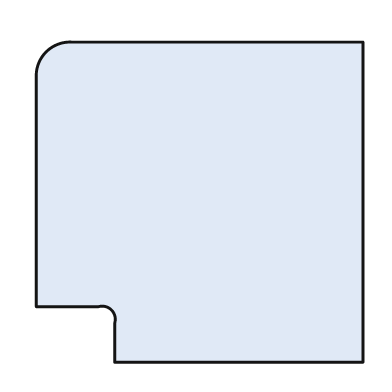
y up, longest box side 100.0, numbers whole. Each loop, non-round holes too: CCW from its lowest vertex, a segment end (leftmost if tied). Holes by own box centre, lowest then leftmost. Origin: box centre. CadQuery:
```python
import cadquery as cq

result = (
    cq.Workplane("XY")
    .moveTo(-26.0, -49.0)
    .lineTo(50.0, -49.0)
    .lineTo(50.0, 49.0)
    .lineTo(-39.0, 49.0)
    .threePointArc((-47.0, 46.0), (-50.0, 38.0))
    .lineTo(-50.0, -32.0)
    .lineTo(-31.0, -32.0)
    .threePointArc((-27.0, -33.0), (-26.0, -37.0))
    .close()
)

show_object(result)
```